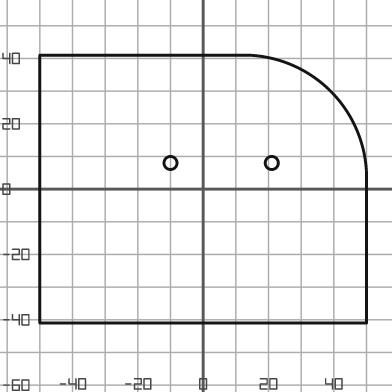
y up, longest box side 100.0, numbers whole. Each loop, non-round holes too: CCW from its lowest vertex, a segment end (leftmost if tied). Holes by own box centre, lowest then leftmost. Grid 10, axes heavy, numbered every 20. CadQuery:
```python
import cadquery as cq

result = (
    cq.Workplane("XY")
    .moveTo(-50.0, -41.0)
    .lineTo(50.0, -41.0)
    .lineTo(50.0, 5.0)
    .threePointArc((39.0, 30.0), (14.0, 41.0))
    .lineTo(-50.0, 41.0)
    .close()
    .moveTo(-10.0, 8.0)
    .circle(2.0)
    .moveTo(21.0, 8.0)
    .circle(2.0)
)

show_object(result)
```